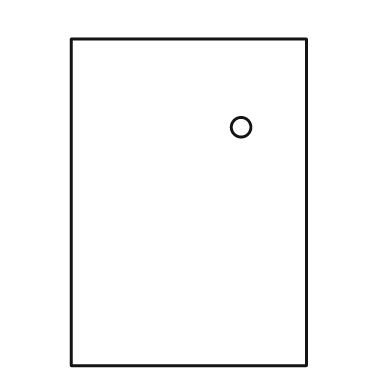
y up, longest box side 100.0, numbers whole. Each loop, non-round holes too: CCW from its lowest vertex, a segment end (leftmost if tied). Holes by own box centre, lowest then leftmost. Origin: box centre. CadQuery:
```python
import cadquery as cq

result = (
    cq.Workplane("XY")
    .moveTo(-36.0, -50.0)
    .lineTo(36.0, -50.0)
    .lineTo(36.0, 50.0)
    .lineTo(-36.0, 50.0)
    .close()
    .moveTo(16.0, 23.0)
    .circle(3.0)
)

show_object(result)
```